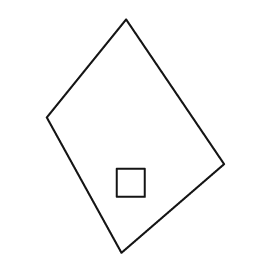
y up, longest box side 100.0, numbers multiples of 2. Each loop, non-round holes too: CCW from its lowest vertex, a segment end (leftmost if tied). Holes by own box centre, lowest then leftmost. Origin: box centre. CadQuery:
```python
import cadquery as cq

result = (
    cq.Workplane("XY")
    .moveTo(-6.0, -50.0)
    .lineTo(38.0, -12.0)
    .lineTo(-4.0, 50.0)
    .lineTo(-38.0, 8.0)
    .close()
    .moveTo(-8.0, -26.0)
    .lineTo(4.0, -26.0)
    .lineTo(4.0, -14.0)
    .lineTo(-8.0, -14.0)
    .close()
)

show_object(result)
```